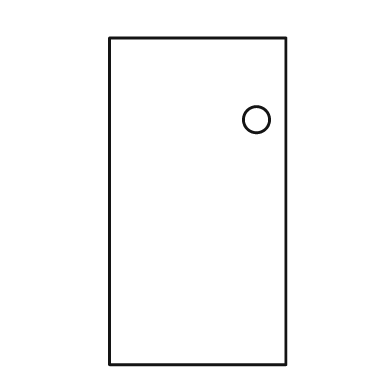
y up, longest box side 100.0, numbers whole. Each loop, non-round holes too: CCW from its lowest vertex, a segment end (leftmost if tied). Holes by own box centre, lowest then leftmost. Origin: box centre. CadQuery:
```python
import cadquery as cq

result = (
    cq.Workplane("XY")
    .moveTo(-27.0, -50.0)
    .lineTo(27.0, -50.0)
    .lineTo(27.0, 50.0)
    .lineTo(-27.0, 50.0)
    .close()
    .moveTo(18.0, 25.0)
    .circle(4.0)
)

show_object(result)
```